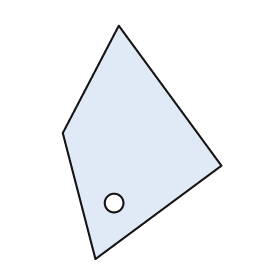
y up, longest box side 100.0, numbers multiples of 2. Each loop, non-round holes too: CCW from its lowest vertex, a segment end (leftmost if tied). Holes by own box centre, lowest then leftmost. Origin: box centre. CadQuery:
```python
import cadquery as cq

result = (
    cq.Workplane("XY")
    .moveTo(-20.0, -50.0)
    .lineTo(34.0, -10.0)
    .lineTo(-10.0, 50.0)
    .lineTo(-34.0, 4.0)
    .close()
    .moveTo(-12.0, -26.0)
    .circle(4.0)
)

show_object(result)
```